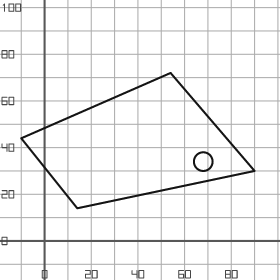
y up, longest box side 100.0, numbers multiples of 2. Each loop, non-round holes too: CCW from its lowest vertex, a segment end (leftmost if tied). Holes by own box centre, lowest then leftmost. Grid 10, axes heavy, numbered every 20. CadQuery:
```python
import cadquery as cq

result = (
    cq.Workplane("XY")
    .moveTo(14.0, 14.0)
    .lineTo(90.0, 30.0)
    .lineTo(54.0, 72.0)
    .lineTo(-10.0, 44.0)
    .close()
    .moveTo(68.0, 34.0)
    .circle(4.0)
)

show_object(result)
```